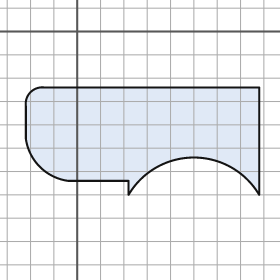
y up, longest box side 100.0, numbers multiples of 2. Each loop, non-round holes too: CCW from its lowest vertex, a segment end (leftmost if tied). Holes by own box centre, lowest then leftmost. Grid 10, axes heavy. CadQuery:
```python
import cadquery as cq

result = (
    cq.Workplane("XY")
    .moveTo(22.0, -70.0)
    .threePointArc((50.0, -54.0), (78.0, -70.0))
    .lineTo(78.0, -24.0)
    .lineTo(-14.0, -24.0)
    .threePointArc((-20.0, -26.0), (-22.0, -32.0))
    .lineTo(-22.0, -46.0)
    .threePointArc((-16.0, -58.0), (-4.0, -64.0))
    .lineTo(22.0, -64.0)
    .close()
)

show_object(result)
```